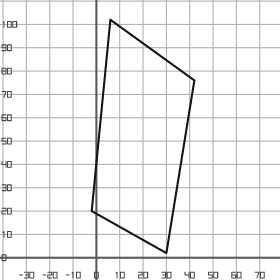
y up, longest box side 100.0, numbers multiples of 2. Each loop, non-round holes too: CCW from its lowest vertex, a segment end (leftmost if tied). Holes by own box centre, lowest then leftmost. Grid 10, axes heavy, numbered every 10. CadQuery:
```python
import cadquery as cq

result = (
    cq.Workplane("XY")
    .moveTo(30.0, 2.0)
    .lineTo(42.0, 76.0)
    .lineTo(6.0, 102.0)
    .lineTo(-2.0, 20.0)
    .close()
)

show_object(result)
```